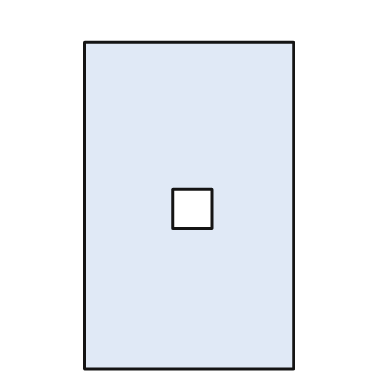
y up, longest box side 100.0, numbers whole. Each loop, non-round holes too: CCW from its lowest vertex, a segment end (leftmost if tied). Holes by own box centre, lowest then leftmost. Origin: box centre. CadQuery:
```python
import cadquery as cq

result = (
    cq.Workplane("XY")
    .moveTo(-32.0, -50.0)
    .lineTo(32.0, -50.0)
    .lineTo(32.0, 50.0)
    .lineTo(-32.0, 50.0)
    .close()
    .moveTo(-5.0, -7.0)
    .lineTo(7.0, -7.0)
    .lineTo(7.0, 5.0)
    .lineTo(-5.0, 5.0)
    .close()
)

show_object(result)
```